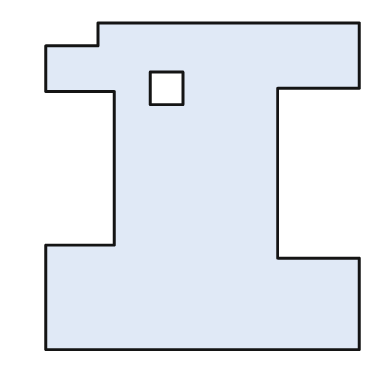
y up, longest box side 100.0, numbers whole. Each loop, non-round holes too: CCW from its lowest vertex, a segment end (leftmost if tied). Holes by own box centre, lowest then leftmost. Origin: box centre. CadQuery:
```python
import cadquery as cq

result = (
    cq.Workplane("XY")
    .moveTo(-48.0, -50.0)
    .lineTo(48.0, -50.0)
    .lineTo(48.0, -22.0)
    .lineTo(23.0, -22.0)
    .lineTo(23.0, 30.0)
    .lineTo(48.0, 30.0)
    .lineTo(48.0, 50.0)
    .lineTo(-32.0, 50.0)
    .lineTo(-32.0, 43.0)
    .lineTo(-48.0, 43.0)
    .lineTo(-48.0, 29.0)
    .lineTo(-27.0, 29.0)
    .lineTo(-27.0, -18.0)
    .lineTo(-48.0, -18.0)
    .close()
    .moveTo(-16.0, 25.0)
    .lineTo(-6.0, 25.0)
    .lineTo(-6.0, 35.0)
    .lineTo(-16.0, 35.0)
    .close()
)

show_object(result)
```